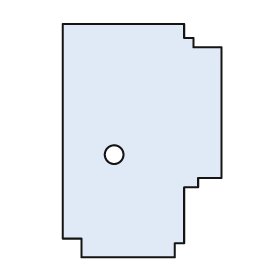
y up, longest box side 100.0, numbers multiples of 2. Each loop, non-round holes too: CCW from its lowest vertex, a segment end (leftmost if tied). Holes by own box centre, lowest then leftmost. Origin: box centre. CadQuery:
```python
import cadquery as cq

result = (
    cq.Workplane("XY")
    .moveTo(-26.0, -50.0)
    .lineTo(14.0, -50.0)
    .lineTo(14.0, -44.0)
    .lineTo(18.0, -44.0)
    .lineTo(18.0, -20.0)
    .lineTo(24.0, -20.0)
    .lineTo(24.0, -16.0)
    .lineTo(34.0, -16.0)
    .lineTo(34.0, 40.0)
    .lineTo(22.0, 40.0)
    .lineTo(22.0, 44.0)
    .lineTo(18.0, 44.0)
    .lineTo(18.0, 50.0)
    .lineTo(-34.0, 50.0)
    .lineTo(-34.0, -42.0)
    .lineTo(-26.0, -42.0)
    .close()
    .moveTo(-12.0, -6.0)
    .circle(4.0)
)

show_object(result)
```